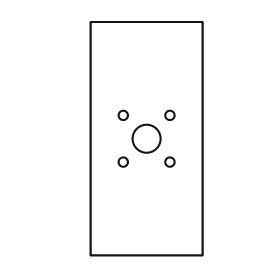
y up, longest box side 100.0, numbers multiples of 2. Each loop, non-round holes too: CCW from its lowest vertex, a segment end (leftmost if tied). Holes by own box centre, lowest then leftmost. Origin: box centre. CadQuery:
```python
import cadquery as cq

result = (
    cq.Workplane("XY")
    .moveTo(-24.0, -50.0)
    .lineTo(24.0, -50.0)
    .lineTo(24.0, 50.0)
    .lineTo(-24.0, 50.0)
    .close()
    .moveTo(-10.0, -10.0)
    .circle(2.0)
    .moveTo(10.0, -10.0)
    .circle(2.0)
    .moveTo(0.0, 0.0)
    .circle(6.0)
    .moveTo(-10.0, 10.0)
    .circle(2.0)
    .moveTo(10.0, 10.0)
    .circle(2.0)
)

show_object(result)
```